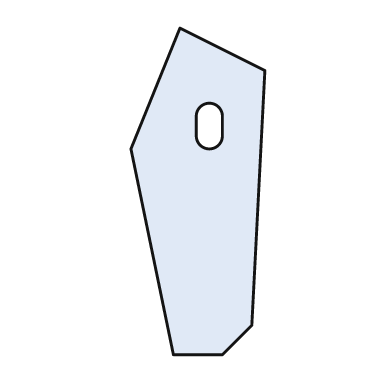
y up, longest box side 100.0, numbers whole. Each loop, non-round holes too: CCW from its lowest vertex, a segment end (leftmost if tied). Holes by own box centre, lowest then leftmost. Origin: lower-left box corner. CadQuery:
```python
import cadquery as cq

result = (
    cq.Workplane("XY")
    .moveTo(13.0, 0.0)
    .lineTo(28.0, 0.0)
    .lineTo(37.0, 9.0)
    .lineTo(41.0, 87.0)
    .lineTo(15.0, 100.0)
    .lineTo(0.0, 63.0)
    .close()
    .moveTo(20.0, 67.0)
    .threePointArc((24.0, 63.0), (28.0, 67.0))
    .lineTo(28.0, 73.0)
    .threePointArc((24.0, 77.0), (20.0, 73.0))
    .close()
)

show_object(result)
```